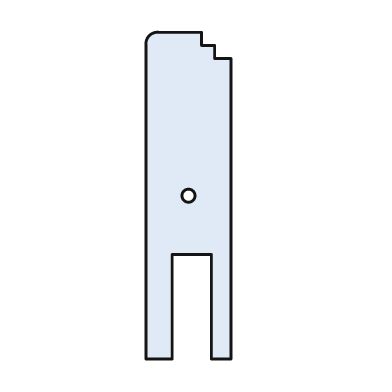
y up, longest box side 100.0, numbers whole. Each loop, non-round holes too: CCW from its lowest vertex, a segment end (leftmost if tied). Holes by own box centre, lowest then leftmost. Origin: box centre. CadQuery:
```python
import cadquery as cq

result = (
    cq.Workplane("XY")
    .moveTo(-13.0, -50.0)
    .lineTo(-5.0, -50.0)
    .lineTo(-5.0, -18.0)
    .lineTo(7.0, -18.0)
    .lineTo(7.0, -50.0)
    .lineTo(13.0, -50.0)
    .lineTo(13.0, 42.0)
    .lineTo(8.0, 42.0)
    .lineTo(8.0, 46.0)
    .lineTo(4.0, 46.0)
    .lineTo(4.0, 50.0)
    .lineTo(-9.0, 50.0)
    .threePointArc((-12.0, 49.0), (-13.0, 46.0))
    .close()
    .moveTo(0.0, 0.0)
    .circle(2.0)
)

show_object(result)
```